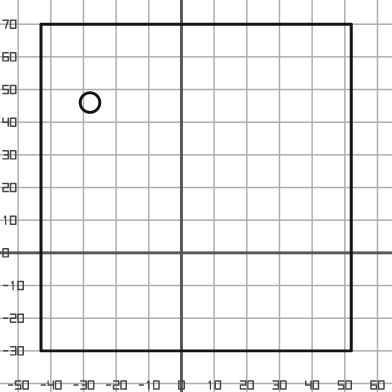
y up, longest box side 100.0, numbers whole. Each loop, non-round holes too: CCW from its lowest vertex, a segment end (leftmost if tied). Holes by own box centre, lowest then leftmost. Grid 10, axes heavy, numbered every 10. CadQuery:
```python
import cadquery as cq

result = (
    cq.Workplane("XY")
    .moveTo(-43.0, -30.0)
    .lineTo(52.0, -30.0)
    .lineTo(52.0, 70.0)
    .lineTo(-43.0, 70.0)
    .close()
    .moveTo(-28.0, 46.0)
    .circle(3.0)
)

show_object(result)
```